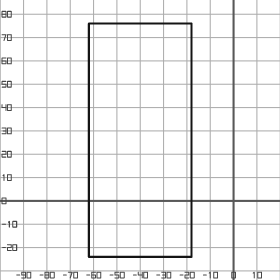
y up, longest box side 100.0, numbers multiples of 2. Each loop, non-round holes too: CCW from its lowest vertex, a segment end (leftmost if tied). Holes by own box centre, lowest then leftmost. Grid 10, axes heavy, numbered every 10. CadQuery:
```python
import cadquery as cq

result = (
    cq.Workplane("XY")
    .moveTo(-62.0, -24.0)
    .lineTo(-18.0, -24.0)
    .lineTo(-18.0, 76.0)
    .lineTo(-62.0, 76.0)
    .close()
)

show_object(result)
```